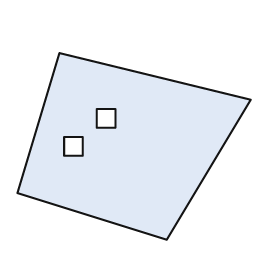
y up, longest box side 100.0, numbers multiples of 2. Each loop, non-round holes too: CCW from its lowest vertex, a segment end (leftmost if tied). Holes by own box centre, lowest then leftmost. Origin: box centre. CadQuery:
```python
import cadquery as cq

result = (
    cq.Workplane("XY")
    .moveTo(14.0, -40.0)
    .lineTo(50.0, 20.0)
    .lineTo(-32.0, 40.0)
    .lineTo(-50.0, -20.0)
    .close()
    .moveTo(-30.0, -4.0)
    .lineTo(-22.0, -4.0)
    .lineTo(-22.0, 4.0)
    .lineTo(-30.0, 4.0)
    .close()
    .moveTo(-16.0, 8.0)
    .lineTo(-8.0, 8.0)
    .lineTo(-8.0, 16.0)
    .lineTo(-16.0, 16.0)
    .close()
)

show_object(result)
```